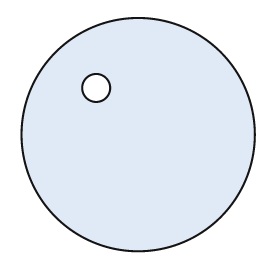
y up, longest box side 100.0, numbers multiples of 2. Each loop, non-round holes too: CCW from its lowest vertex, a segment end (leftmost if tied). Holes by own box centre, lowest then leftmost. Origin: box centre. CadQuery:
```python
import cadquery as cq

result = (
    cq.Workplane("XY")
    .moveTo(0.0, 0.0)
    .circle(50.0)
    .moveTo(-18.0, 20.0)
    .circle(6.0)
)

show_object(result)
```